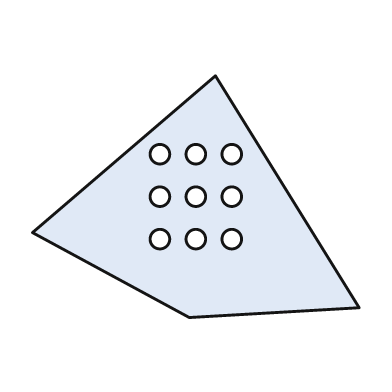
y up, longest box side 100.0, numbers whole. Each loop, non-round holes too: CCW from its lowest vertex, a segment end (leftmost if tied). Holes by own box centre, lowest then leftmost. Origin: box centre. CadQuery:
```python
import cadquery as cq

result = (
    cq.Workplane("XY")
    .moveTo(-2.0, -37.0)
    .lineTo(50.0, -34.0)
    .lineTo(6.0, 37.0)
    .lineTo(-50.0, -11.0)
    .close()
    .moveTo(-11.0, -13.0)
    .circle(3.0)
    .moveTo(0.0, -13.0)
    .circle(3.0)
    .moveTo(11.0, -13.0)
    .circle(3.0)
    .moveTo(-11.0, 0.0)
    .circle(3.0)
    .moveTo(0.0, 0.0)
    .circle(3.0)
    .moveTo(11.0, 0.0)
    .circle(3.0)
    .moveTo(-11.0, 13.0)
    .circle(3.0)
    .moveTo(0.0, 13.0)
    .circle(3.0)
    .moveTo(11.0, 13.0)
    .circle(3.0)
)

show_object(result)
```